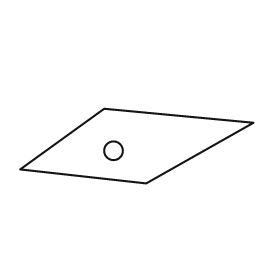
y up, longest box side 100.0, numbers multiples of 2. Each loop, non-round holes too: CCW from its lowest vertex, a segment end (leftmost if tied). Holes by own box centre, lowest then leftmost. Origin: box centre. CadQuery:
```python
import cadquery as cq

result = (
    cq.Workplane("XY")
    .moveTo(4.0, -16.0)
    .lineTo(50.0, 10.0)
    .lineTo(-14.0, 16.0)
    .lineTo(-50.0, -10.0)
    .close()
    .moveTo(-10.0, -2.0)
    .circle(4.0)
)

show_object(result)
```